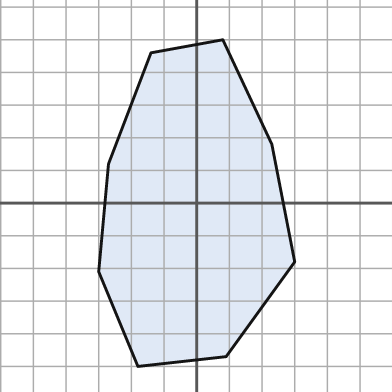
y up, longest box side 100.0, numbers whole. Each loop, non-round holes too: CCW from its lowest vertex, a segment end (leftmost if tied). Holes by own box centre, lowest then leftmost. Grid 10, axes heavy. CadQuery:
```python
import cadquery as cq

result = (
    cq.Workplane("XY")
    .moveTo(-18.0, -50.0)
    .lineTo(9.0, -47.0)
    .lineTo(30.0, -18.0)
    .lineTo(23.0, 18.0)
    .lineTo(8.0, 50.0)
    .lineTo(-14.0, 46.0)
    .lineTo(-27.0, 12.0)
    .lineTo(-30.0, -21.0)
    .close()
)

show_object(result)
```